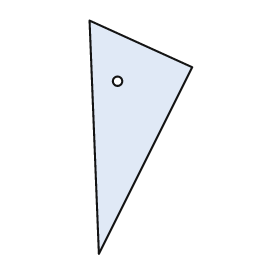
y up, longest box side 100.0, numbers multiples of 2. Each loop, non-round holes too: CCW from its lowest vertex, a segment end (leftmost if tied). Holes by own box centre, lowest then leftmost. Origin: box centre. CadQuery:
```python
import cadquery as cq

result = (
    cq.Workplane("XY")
    .moveTo(-18.0, -50.0)
    .lineTo(22.0, 30.0)
    .lineTo(-22.0, 50.0)
    .close()
    .moveTo(-10.0, 24.0)
    .circle(2.0)
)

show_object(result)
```